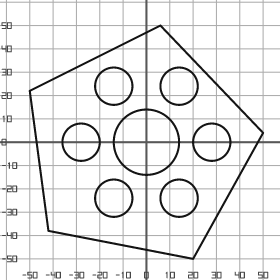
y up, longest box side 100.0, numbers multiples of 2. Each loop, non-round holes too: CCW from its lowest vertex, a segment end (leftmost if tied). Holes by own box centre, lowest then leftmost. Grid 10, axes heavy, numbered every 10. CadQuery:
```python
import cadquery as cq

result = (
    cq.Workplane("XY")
    .moveTo(20.0, -50.0)
    .lineTo(50.0, 4.0)
    .lineTo(6.0, 50.0)
    .lineTo(-50.0, 22.0)
    .lineTo(-42.0, -38.0)
    .close()
    .moveTo(-14.0, -24.0)
    .circle(8.0)
    .moveTo(14.0, -24.0)
    .circle(8.0)
    .moveTo(-28.0, 0.0)
    .circle(8.0)
    .moveTo(0.0, 0.0)
    .circle(14.0)
    .moveTo(28.0, 0.0)
    .circle(8.0)
    .moveTo(-14.0, 24.0)
    .circle(8.0)
    .moveTo(14.0, 24.0)
    .circle(8.0)
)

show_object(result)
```